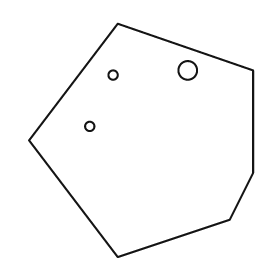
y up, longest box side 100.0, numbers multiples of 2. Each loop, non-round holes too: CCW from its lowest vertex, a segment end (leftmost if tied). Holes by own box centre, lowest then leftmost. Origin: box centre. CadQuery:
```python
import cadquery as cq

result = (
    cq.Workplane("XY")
    .moveTo(-10.0, -50.0)
    .lineTo(38.0, -34.0)
    .lineTo(48.0, -14.0)
    .lineTo(48.0, 30.0)
    .lineTo(-10.0, 50.0)
    .lineTo(-48.0, 0.0)
    .close()
    .moveTo(-22.0, 6.0)
    .circle(2.0)
    .moveTo(-12.0, 28.0)
    .circle(2.0)
    .moveTo(20.0, 30.0)
    .circle(4.0)
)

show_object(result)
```